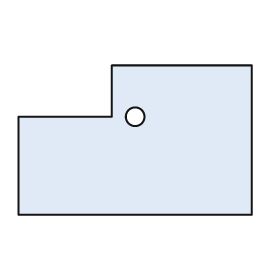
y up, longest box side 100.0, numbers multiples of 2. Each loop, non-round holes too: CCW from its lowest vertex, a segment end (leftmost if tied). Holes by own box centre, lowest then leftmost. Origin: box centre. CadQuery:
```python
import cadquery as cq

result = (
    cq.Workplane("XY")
    .moveTo(-50.0, -32.0)
    .lineTo(50.0, -32.0)
    .lineTo(50.0, 32.0)
    .lineTo(-10.0, 32.0)
    .lineTo(-10.0, 10.0)
    .lineTo(-50.0, 10.0)
    .close()
    .moveTo(0.0, 10.0)
    .circle(4.0)
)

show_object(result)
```